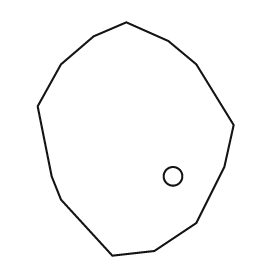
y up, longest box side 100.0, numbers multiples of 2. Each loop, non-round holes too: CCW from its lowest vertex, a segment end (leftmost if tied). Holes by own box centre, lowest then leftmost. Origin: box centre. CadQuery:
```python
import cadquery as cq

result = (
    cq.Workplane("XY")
    .moveTo(-10.0, -50.0)
    .lineTo(8.0, -48.0)
    .lineTo(26.0, -36.0)
    .lineTo(38.0, -12.0)
    .lineTo(42.0, 6.0)
    .lineTo(26.0, 32.0)
    .lineTo(14.0, 42.0)
    .lineTo(-4.0, 50.0)
    .lineTo(-18.0, 44.0)
    .lineTo(-32.0, 32.0)
    .lineTo(-42.0, 14.0)
    .lineTo(-36.0, -16.0)
    .lineTo(-32.0, -26.0)
    .close()
    .moveTo(16.0, -16.0)
    .circle(4.0)
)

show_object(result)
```